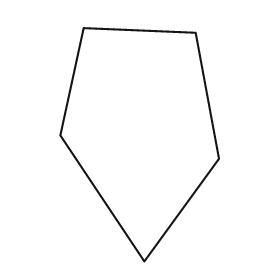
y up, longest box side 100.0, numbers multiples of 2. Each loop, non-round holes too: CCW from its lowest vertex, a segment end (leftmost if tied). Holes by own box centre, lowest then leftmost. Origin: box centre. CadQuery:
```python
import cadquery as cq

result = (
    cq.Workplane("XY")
    .moveTo(2.0, -50.0)
    .lineTo(34.0, -6.0)
    .lineTo(24.0, 48.0)
    .lineTo(-24.0, 50.0)
    .lineTo(-34.0, 4.0)
    .close()
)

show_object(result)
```